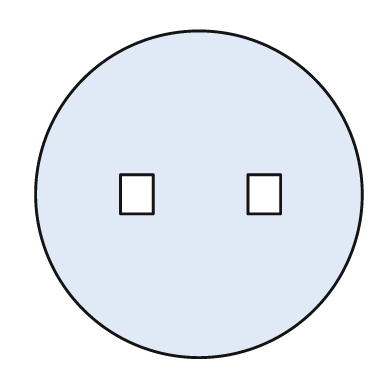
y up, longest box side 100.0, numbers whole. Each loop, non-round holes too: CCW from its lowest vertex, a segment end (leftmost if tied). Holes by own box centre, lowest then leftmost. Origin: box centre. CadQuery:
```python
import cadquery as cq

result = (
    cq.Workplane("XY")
    .moveTo(0.0, 0.0)
    .circle(50.0)
    .moveTo(-24.0, -6.0)
    .lineTo(-14.0, -6.0)
    .lineTo(-14.0, 6.0)
    .lineTo(-24.0, 6.0)
    .close()
    .moveTo(15.0, -6.0)
    .lineTo(25.0, -6.0)
    .lineTo(25.0, 6.0)
    .lineTo(15.0, 6.0)
    .close()
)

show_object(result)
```